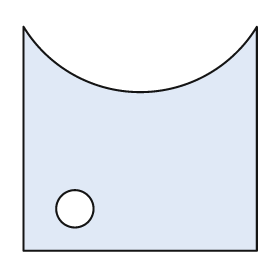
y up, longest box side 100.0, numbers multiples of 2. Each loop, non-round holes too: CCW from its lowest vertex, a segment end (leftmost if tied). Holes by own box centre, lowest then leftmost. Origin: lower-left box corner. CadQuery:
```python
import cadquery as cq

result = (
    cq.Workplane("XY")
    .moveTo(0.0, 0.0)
    .lineTo(100.0, 0.0)
    .lineTo(100.0, 96.0)
    .threePointArc((50.0, 68.0), (0.0, 96.0))
    .close()
    .moveTo(22.0, 18.0)
    .circle(8.0)
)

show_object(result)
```